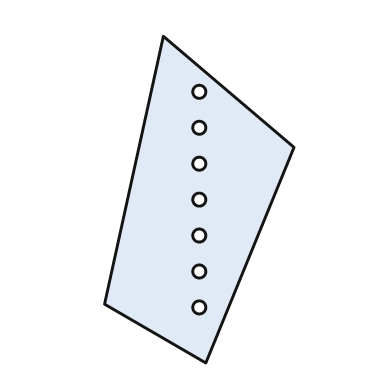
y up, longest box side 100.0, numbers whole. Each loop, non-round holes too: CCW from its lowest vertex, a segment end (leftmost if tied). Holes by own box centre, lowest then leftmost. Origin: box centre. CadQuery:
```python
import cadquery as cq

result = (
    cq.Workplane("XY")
    .moveTo(2.0, -50.0)
    .lineTo(29.0, 16.0)
    .lineTo(-11.0, 50.0)
    .lineTo(-29.0, -32.0)
    .close()
    .moveTo(0.0, -33.0)
    .circle(2.0)
    .moveTo(0.0, -22.0)
    .circle(2.0)
    .moveTo(0.0, -11.0)
    .circle(2.0)
    .moveTo(0.0, 0.0)
    .circle(2.0)
    .moveTo(0.0, 11.0)
    .circle(2.0)
    .moveTo(0.0, 22.0)
    .circle(2.0)
    .moveTo(0.0, 33.0)
    .circle(2.0)
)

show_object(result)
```